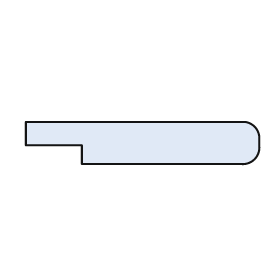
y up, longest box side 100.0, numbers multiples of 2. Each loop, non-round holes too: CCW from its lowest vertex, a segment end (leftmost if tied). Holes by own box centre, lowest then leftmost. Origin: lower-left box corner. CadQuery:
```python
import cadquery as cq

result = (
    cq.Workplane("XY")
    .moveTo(24.0, 0.0)
    .lineTo(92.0, 0.0)
    .threePointArc((98.0, 2.0), (100.0, 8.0))
    .lineTo(100.0, 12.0)
    .threePointArc((98.0, 16.0), (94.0, 18.0))
    .lineTo(0.0, 18.0)
    .lineTo(0.0, 8.0)
    .lineTo(24.0, 8.0)
    .close()
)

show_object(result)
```